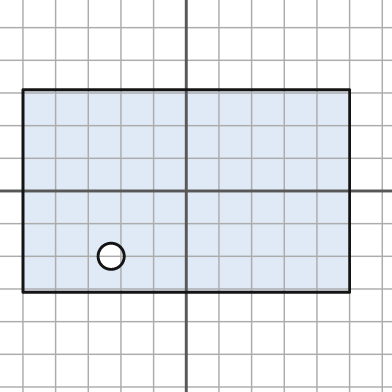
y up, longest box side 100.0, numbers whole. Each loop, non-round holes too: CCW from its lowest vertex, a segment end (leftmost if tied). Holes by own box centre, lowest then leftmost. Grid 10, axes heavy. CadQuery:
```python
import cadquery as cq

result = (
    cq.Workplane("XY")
    .moveTo(-50.0, -31.0)
    .lineTo(50.0, -31.0)
    .lineTo(50.0, 31.0)
    .lineTo(-50.0, 31.0)
    .close()
    .moveTo(-23.0, -20.0)
    .circle(4.0)
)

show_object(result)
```